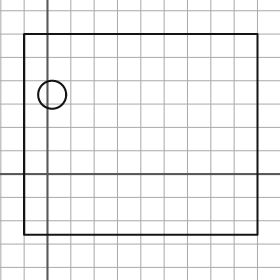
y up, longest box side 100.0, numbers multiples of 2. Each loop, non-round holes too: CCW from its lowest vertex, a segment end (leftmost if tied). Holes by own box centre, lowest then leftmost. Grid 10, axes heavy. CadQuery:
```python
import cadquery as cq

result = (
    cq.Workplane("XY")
    .moveTo(-10.0, -26.0)
    .lineTo(90.0, -26.0)
    .lineTo(90.0, 60.0)
    .lineTo(-10.0, 60.0)
    .close()
    .moveTo(2.0, 34.0)
    .circle(6.0)
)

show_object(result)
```